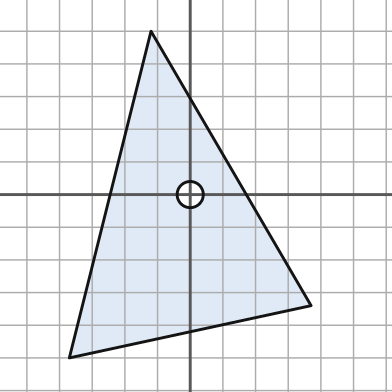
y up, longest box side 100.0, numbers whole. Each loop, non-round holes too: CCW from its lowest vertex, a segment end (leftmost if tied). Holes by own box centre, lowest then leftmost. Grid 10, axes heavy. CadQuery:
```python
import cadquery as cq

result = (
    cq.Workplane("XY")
    .moveTo(-37.0, -50.0)
    .lineTo(37.0, -34.0)
    .lineTo(-12.0, 50.0)
    .close()
    .moveTo(0.0, 0.0)
    .circle(4.0)
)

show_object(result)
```